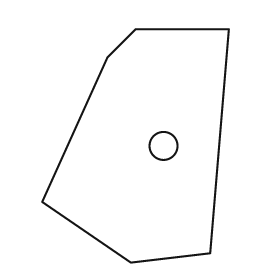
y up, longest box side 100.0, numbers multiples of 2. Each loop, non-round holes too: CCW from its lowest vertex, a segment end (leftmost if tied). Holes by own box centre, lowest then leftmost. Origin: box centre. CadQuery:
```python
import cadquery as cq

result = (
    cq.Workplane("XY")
    .moveTo(-2.0, -50.0)
    .lineTo(32.0, -46.0)
    .lineTo(40.0, 50.0)
    .lineTo(0.0, 50.0)
    .lineTo(-12.0, 38.0)
    .lineTo(-40.0, -24.0)
    .close()
    .moveTo(12.0, 0.0)
    .circle(6.0)
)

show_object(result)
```